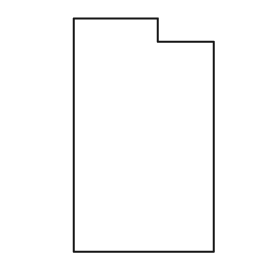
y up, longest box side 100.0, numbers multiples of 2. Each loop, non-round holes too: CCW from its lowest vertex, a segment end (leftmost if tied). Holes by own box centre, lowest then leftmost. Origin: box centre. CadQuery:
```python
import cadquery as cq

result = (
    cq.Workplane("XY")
    .moveTo(-30.0, -50.0)
    .lineTo(30.0, -50.0)
    .lineTo(30.0, 40.0)
    .lineTo(6.0, 40.0)
    .lineTo(6.0, 50.0)
    .lineTo(-30.0, 50.0)
    .close()
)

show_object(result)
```